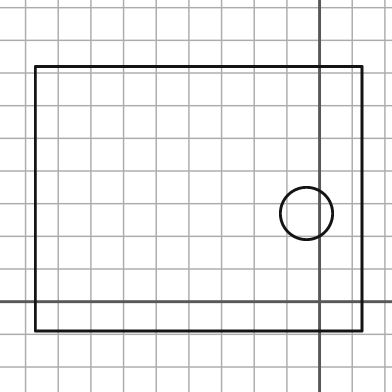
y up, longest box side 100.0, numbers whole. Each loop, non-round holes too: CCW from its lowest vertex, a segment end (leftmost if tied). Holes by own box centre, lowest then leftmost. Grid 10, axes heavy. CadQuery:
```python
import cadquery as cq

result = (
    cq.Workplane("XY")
    .moveTo(-87.0, -9.0)
    .lineTo(13.0, -9.0)
    .lineTo(13.0, 72.0)
    .lineTo(-87.0, 72.0)
    .close()
    .moveTo(-4.0, 27.0)
    .circle(8.0)
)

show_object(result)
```